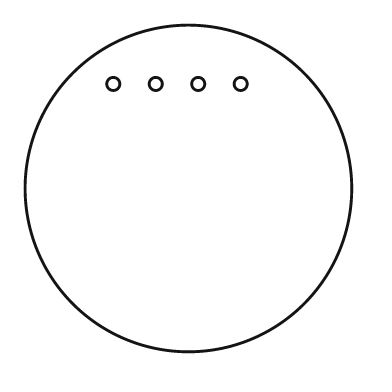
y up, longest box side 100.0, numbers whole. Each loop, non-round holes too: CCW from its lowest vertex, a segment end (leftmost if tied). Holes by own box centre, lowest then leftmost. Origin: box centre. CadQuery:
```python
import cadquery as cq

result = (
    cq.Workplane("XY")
    .moveTo(0.0, 0.0)
    .circle(50.0)
    .moveTo(-23.0, 32.0)
    .circle(2.0)
    .moveTo(-10.0, 32.0)
    .circle(2.0)
    .moveTo(3.0, 32.0)
    .circle(2.0)
    .moveTo(16.0, 32.0)
    .circle(2.0)
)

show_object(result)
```